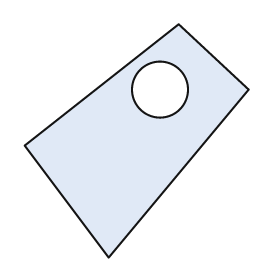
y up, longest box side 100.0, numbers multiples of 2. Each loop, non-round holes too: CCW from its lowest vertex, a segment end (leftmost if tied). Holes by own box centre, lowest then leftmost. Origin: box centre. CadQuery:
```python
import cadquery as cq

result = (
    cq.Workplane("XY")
    .moveTo(-12.0, -50.0)
    .lineTo(48.0, 22.0)
    .lineTo(18.0, 50.0)
    .lineTo(-48.0, -2.0)
    .close()
    .moveTo(10.0, 22.0)
    .circle(12.0)
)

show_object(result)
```